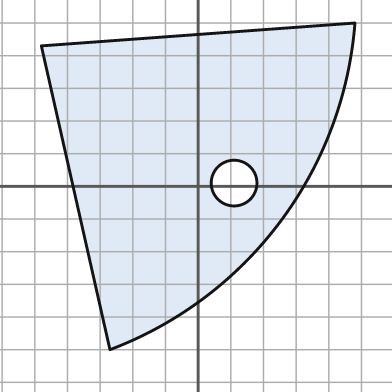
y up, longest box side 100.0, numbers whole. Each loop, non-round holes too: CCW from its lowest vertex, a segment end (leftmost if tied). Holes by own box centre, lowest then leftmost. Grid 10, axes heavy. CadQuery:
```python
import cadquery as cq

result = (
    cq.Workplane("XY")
    .moveTo(-27.0, -50.0)
    .threePointArc((25.0, -11.0), (48.0, 50.0))
    .lineTo(-48.0, 43.0)
    .close()
    .moveTo(11.0, 1.0)
    .circle(7.0)
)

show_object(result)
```